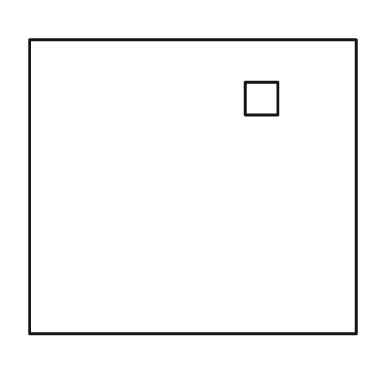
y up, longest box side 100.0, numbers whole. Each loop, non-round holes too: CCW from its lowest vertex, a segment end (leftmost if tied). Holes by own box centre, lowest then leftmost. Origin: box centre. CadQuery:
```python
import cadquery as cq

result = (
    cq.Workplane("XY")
    .moveTo(-50.0, -45.0)
    .lineTo(50.0, -45.0)
    .lineTo(50.0, 45.0)
    .lineTo(-50.0, 45.0)
    .close()
    .moveTo(16.0, 22.0)
    .lineTo(26.0, 22.0)
    .lineTo(26.0, 32.0)
    .lineTo(16.0, 32.0)
    .close()
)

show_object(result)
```